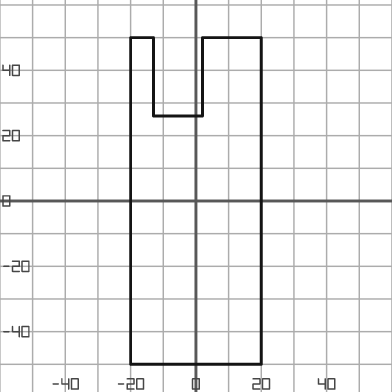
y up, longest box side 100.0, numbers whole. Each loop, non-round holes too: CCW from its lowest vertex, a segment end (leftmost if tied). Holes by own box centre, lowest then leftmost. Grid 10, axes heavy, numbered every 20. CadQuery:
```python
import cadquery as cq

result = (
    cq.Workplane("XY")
    .moveTo(-20.0, -50.0)
    .lineTo(20.0, -50.0)
    .lineTo(20.0, 50.0)
    .lineTo(2.0, 50.0)
    .lineTo(2.0, 26.0)
    .lineTo(-13.0, 26.0)
    .lineTo(-13.0, 50.0)
    .lineTo(-20.0, 50.0)
    .close()
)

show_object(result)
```